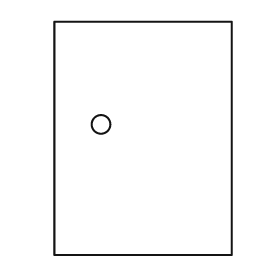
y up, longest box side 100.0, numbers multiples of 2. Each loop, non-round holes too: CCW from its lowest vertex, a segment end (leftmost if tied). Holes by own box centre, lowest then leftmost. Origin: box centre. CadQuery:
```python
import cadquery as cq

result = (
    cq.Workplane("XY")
    .moveTo(-38.0, -50.0)
    .lineTo(38.0, -50.0)
    .lineTo(38.0, 50.0)
    .lineTo(-38.0, 50.0)
    .close()
    .moveTo(-18.0, 6.0)
    .circle(4.0)
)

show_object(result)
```